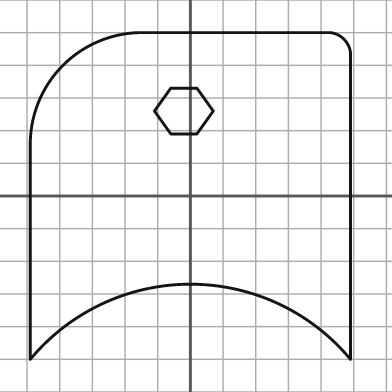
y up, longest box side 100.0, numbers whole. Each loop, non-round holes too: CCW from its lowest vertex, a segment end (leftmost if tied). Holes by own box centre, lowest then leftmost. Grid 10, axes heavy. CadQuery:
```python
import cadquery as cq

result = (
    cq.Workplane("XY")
    .moveTo(-49.0, -50.0)
    .threePointArc((0.0, -27.0), (49.0, -50.0))
    .lineTo(49.0, 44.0)
    .threePointArc((47.0, 48.0), (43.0, 50.0))
    .lineTo(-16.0, 50.0)
    .threePointArc((-39.0, 40.0), (-49.0, 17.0))
    .close()
    .moveTo(-6.0, 19.0)
    .lineTo(2.0, 19.0)
    .lineTo(7.0, 26.0)
    .lineTo(2.0, 33.0)
    .lineTo(-6.0, 33.0)
    .lineTo(-11.0, 26.0)
    .close()
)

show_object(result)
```